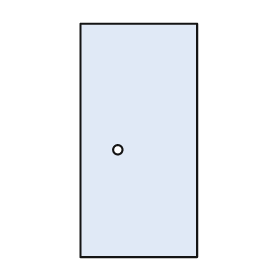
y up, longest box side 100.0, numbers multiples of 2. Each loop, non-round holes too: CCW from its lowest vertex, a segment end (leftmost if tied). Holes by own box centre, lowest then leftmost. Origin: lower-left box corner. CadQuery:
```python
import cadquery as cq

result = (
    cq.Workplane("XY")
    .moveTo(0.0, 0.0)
    .lineTo(50.0, 0.0)
    .lineTo(50.0, 100.0)
    .lineTo(0.0, 100.0)
    .close()
    .moveTo(16.0, 46.0)
    .circle(2.0)
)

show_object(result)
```